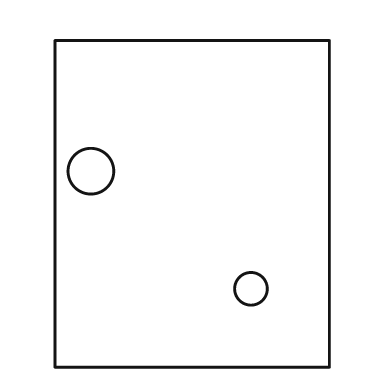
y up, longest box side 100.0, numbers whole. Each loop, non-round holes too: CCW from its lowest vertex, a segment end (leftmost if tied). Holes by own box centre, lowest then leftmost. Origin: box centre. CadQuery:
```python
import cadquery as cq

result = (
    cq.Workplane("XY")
    .moveTo(-42.0, -50.0)
    .lineTo(42.0, -50.0)
    .lineTo(42.0, 50.0)
    .lineTo(-42.0, 50.0)
    .close()
    .moveTo(18.0, -26.0)
    .circle(5.0)
    .moveTo(-31.0, 10.0)
    .circle(7.0)
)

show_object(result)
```